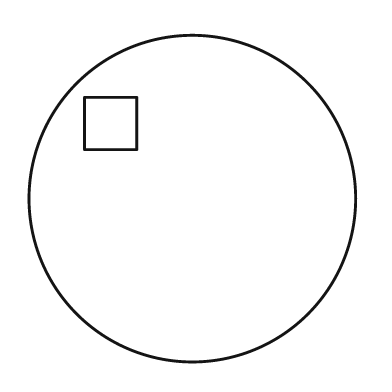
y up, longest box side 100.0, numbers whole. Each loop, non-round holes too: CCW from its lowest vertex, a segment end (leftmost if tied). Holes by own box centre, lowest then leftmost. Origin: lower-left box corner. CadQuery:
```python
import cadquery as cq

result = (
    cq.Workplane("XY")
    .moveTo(50.0, 50.0)
    .circle(50.0)
    .moveTo(17.0, 65.0)
    .lineTo(33.0, 65.0)
    .lineTo(33.0, 81.0)
    .lineTo(17.0, 81.0)
    .close()
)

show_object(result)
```